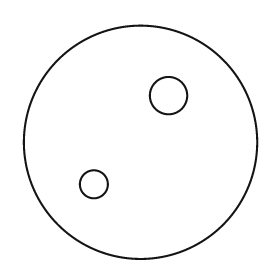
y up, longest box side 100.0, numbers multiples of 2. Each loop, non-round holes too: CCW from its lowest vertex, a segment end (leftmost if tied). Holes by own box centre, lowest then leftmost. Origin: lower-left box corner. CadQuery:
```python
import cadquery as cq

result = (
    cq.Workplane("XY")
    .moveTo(50.0, 50.0)
    .circle(50.0)
    .moveTo(30.0, 32.0)
    .circle(6.0)
    .moveTo(62.0, 70.0)
    .circle(8.0)
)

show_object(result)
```